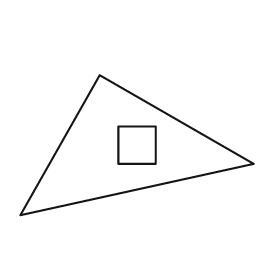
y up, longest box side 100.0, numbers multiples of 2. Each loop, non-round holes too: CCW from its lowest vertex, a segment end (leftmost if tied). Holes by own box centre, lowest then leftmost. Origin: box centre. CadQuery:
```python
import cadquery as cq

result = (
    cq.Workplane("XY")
    .moveTo(-50.0, -30.0)
    .lineTo(50.0, -8.0)
    .lineTo(-16.0, 30.0)
    .close()
    .moveTo(-8.0, -8.0)
    .lineTo(8.0, -8.0)
    .lineTo(8.0, 8.0)
    .lineTo(-8.0, 8.0)
    .close()
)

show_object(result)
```